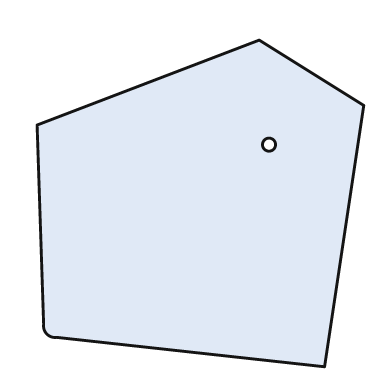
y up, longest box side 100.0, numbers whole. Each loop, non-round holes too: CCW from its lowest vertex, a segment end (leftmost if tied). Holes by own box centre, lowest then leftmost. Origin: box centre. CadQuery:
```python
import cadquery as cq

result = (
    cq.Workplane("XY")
    .moveTo(38.0, -50.0)
    .lineTo(50.0, 30.0)
    .lineTo(18.0, 50.0)
    .lineTo(-50.0, 24.0)
    .lineTo(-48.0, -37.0)
    .threePointArc((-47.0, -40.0), (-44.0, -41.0))
    .close()
    .moveTo(21.0, 18.0)
    .circle(2.0)
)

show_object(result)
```